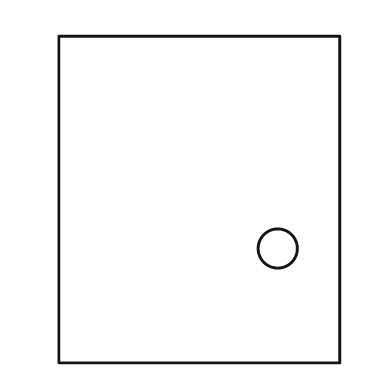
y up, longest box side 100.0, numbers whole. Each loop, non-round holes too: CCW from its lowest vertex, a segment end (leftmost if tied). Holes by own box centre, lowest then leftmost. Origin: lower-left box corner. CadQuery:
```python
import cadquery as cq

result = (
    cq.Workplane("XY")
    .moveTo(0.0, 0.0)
    .lineTo(86.0, 0.0)
    .lineTo(86.0, 100.0)
    .lineTo(0.0, 100.0)
    .close()
    .moveTo(67.0, 35.0)
    .circle(6.0)
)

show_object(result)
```